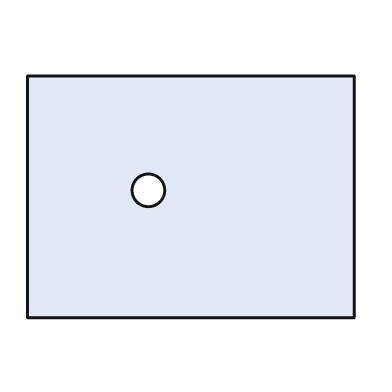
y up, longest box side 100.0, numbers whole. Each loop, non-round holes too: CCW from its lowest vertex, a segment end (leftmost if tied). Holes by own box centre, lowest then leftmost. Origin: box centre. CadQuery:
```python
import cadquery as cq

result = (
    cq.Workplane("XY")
    .moveTo(-50.0, -37.0)
    .lineTo(50.0, -37.0)
    .lineTo(50.0, 37.0)
    .lineTo(-50.0, 37.0)
    .close()
    .moveTo(-13.0, 2.0)
    .circle(5.0)
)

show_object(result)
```